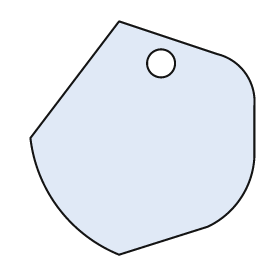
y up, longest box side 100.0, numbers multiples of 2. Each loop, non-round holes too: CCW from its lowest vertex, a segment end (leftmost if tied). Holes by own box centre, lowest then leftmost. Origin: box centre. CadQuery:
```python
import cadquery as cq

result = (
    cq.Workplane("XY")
    .moveTo(-10.0, -50.0)
    .lineTo(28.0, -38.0)
    .threePointArc((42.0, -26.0), (48.0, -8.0))
    .lineTo(48.0, 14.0)
    .threePointArc((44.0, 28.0), (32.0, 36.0))
    .lineTo(-10.0, 50.0)
    .lineTo(-48.0, 0.0)
    .threePointArc((-36.0, -30.0), (-10.0, -50.0))
    .close()
    .moveTo(8.0, 32.0)
    .circle(6.0)
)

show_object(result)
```